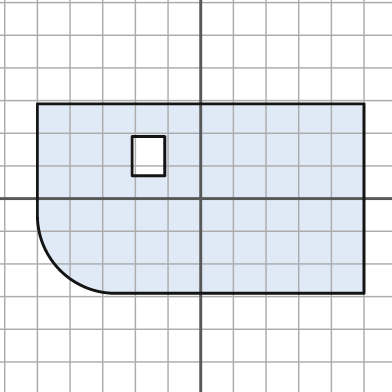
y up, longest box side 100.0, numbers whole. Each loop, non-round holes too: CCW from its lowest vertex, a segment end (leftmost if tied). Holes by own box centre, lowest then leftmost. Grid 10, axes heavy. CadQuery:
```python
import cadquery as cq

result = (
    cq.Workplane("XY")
    .moveTo(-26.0, -29.0)
    .lineTo(50.0, -29.0)
    .lineTo(50.0, 29.0)
    .lineTo(-50.0, 29.0)
    .lineTo(-50.0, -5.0)
    .threePointArc((-43.0, -22.0), (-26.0, -29.0))
    .close()
    .moveTo(-21.0, 7.0)
    .lineTo(-11.0, 7.0)
    .lineTo(-11.0, 19.0)
    .lineTo(-21.0, 19.0)
    .close()
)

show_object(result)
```